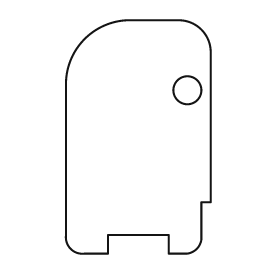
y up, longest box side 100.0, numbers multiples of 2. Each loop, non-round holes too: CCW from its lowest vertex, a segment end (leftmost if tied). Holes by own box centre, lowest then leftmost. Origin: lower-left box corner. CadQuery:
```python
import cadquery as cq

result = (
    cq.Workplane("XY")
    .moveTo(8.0, 0.0)
    .lineTo(18.0, 0.0)
    .lineTo(18.0, 8.0)
    .lineTo(44.0, 8.0)
    .lineTo(44.0, 0.0)
    .lineTo(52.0, 0.0)
    .threePointArc((56.0, 2.0), (58.0, 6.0))
    .lineTo(58.0, 22.0)
    .lineTo(62.0, 22.0)
    .lineTo(62.0, 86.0)
    .threePointArc((58.0, 96.0), (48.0, 100.0))
    .lineTo(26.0, 100.0)
    .threePointArc((8.0, 92.0), (0.0, 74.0))
    .lineTo(0.0, 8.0)
    .threePointArc((2.0, 2.0), (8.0, 0.0))
    .close()
    .moveTo(52.0, 70.0)
    .circle(6.0)
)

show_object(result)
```